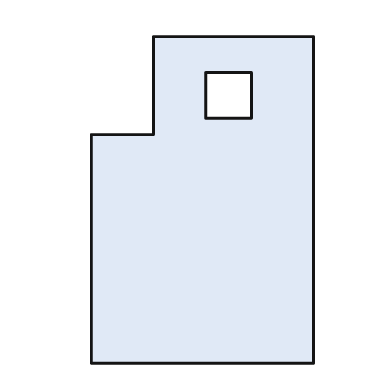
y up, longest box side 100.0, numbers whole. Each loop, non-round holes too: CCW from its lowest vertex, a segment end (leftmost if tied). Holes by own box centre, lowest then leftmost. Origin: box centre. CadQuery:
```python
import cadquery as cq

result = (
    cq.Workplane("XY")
    .moveTo(-34.0, -50.0)
    .lineTo(34.0, -50.0)
    .lineTo(34.0, 50.0)
    .lineTo(-15.0, 50.0)
    .lineTo(-15.0, 20.0)
    .lineTo(-34.0, 20.0)
    .close()
    .moveTo(1.0, 25.0)
    .lineTo(15.0, 25.0)
    .lineTo(15.0, 39.0)
    .lineTo(1.0, 39.0)
    .close()
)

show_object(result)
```